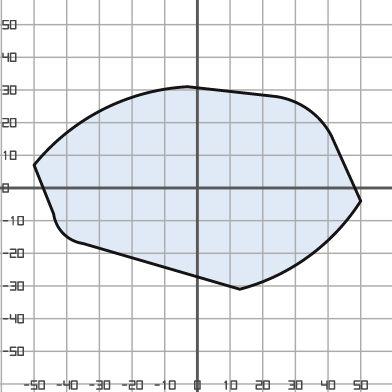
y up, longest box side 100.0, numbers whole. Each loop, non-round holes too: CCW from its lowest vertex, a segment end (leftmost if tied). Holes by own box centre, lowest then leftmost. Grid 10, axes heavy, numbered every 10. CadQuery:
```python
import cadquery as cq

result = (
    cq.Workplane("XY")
    .moveTo(13.0, -31.0)
    .threePointArc((34.0, -21.0), (50.0, -4.0))
    .lineTo(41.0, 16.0)
    .threePointArc((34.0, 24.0), (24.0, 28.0))
    .lineTo(-3.0, 31.0)
    .threePointArc((-29.0, 24.0), (-50.0, 7.0))
    .lineTo(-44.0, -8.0)
    .threePointArc((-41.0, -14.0), (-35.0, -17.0))
    .close()
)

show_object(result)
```